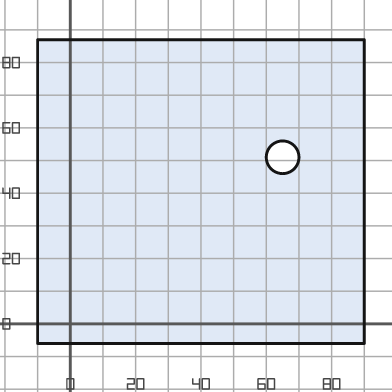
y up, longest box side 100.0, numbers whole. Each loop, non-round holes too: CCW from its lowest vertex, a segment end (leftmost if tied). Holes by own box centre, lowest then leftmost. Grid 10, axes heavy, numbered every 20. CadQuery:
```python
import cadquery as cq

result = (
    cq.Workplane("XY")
    .moveTo(-10.0, -6.0)
    .lineTo(90.0, -6.0)
    .lineTo(90.0, 87.0)
    .lineTo(-10.0, 87.0)
    .close()
    .moveTo(65.0, 51.0)
    .circle(5.0)
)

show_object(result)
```